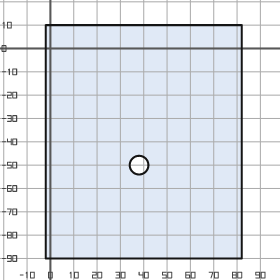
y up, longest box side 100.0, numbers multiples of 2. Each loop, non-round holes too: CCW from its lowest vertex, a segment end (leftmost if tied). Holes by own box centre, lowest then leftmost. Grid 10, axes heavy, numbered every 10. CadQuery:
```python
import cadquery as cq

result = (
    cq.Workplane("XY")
    .moveTo(-2.0, -90.0)
    .lineTo(82.0, -90.0)
    .lineTo(82.0, 10.0)
    .lineTo(-2.0, 10.0)
    .close()
    .moveTo(38.0, -50.0)
    .circle(4.0)
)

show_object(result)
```